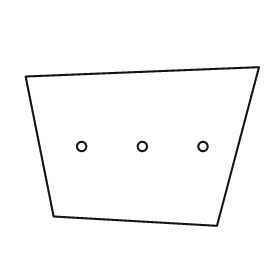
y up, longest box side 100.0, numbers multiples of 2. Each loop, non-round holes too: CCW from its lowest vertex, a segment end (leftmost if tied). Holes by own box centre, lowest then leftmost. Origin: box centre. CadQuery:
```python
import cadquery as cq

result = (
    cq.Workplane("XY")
    .moveTo(32.0, -34.0)
    .lineTo(50.0, 34.0)
    .lineTo(-50.0, 30.0)
    .lineTo(-38.0, -30.0)
    .close()
    .moveTo(-26.0, 0.0)
    .circle(2.0)
    .moveTo(0.0, 0.0)
    .circle(2.0)
    .moveTo(26.0, 0.0)
    .circle(2.0)
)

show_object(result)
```